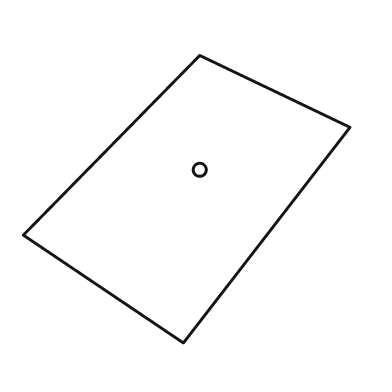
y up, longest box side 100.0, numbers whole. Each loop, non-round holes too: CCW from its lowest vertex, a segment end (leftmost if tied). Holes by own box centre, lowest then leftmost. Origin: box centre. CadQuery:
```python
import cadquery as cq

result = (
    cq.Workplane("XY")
    .moveTo(-1.0, -44.0)
    .lineTo(50.0, 22.0)
    .lineTo(4.0, 44.0)
    .lineTo(-50.0, -11.0)
    .close()
    .moveTo(4.0, 9.0)
    .circle(2.0)
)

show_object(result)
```